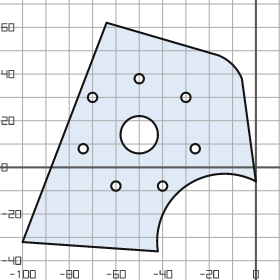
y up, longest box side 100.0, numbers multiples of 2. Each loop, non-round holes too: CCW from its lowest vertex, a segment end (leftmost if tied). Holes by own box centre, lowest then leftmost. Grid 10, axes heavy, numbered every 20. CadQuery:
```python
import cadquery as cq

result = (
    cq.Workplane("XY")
    .moveTo(-42.0, -36.0)
    .threePointArc((-30.0, -8.0), (0.0, -6.0))
    .lineTo(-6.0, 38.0)
    .threePointArc((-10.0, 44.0), (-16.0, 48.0))
    .lineTo(-64.0, 62.0)
    .lineTo(-100.0, -32.0)
    .close()
    .moveTo(-60.0, -8.0)
    .circle(2.0)
    .moveTo(-40.0, -8.0)
    .circle(2.0)
    .moveTo(-74.0, 8.0)
    .circle(2.0)
    .moveTo(-26.0, 8.0)
    .circle(2.0)
    .moveTo(-50.0, 14.0)
    .circle(8.0)
    .moveTo(-70.0, 30.0)
    .circle(2.0)
    .moveTo(-30.0, 30.0)
    .circle(2.0)
    .moveTo(-50.0, 38.0)
    .circle(2.0)
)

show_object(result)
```